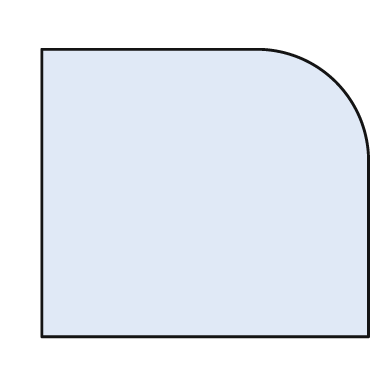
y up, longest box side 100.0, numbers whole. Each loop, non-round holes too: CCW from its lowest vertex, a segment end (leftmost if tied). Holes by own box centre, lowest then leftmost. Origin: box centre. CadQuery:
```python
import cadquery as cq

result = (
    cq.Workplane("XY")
    .moveTo(-50.0, -44.0)
    .lineTo(50.0, -44.0)
    .lineTo(50.0, 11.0)
    .threePointArc((40.0, 34.0), (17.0, 44.0))
    .lineTo(-50.0, 44.0)
    .close()
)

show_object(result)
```